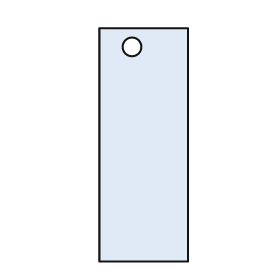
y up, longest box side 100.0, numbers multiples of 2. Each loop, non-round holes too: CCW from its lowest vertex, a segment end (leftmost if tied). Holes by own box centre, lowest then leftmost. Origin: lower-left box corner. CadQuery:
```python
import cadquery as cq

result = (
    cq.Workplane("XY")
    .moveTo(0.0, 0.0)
    .lineTo(38.0, 0.0)
    .lineTo(38.0, 100.0)
    .lineTo(0.0, 100.0)
    .close()
    .moveTo(14.0, 92.0)
    .circle(4.0)
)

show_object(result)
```